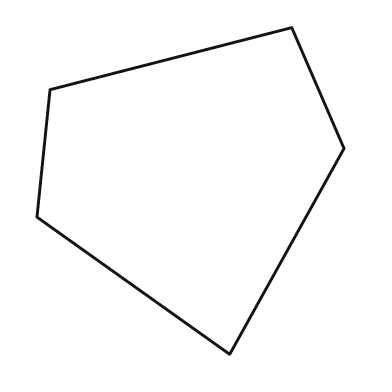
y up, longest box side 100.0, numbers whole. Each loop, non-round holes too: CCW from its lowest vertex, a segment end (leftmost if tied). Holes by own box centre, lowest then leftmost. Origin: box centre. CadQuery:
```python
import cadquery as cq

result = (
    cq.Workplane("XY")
    .moveTo(12.0, -50.0)
    .lineTo(47.0, 13.0)
    .lineTo(31.0, 50.0)
    .lineTo(-43.0, 31.0)
    .lineTo(-47.0, -8.0)
    .close()
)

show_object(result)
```